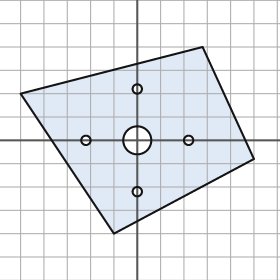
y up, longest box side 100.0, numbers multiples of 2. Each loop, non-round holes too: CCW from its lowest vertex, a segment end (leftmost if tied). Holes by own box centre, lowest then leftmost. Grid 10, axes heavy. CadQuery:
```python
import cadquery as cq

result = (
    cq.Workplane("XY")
    .moveTo(-10.0, -40.0)
    .lineTo(50.0, -8.0)
    .lineTo(28.0, 40.0)
    .lineTo(-50.0, 20.0)
    .close()
    .moveTo(0.0, -22.0)
    .circle(2.0)
    .moveTo(-22.0, 0.0)
    .circle(2.0)
    .moveTo(0.0, 0.0)
    .circle(6.0)
    .moveTo(22.0, 0.0)
    .circle(2.0)
    .moveTo(0.0, 22.0)
    .circle(2.0)
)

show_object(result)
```